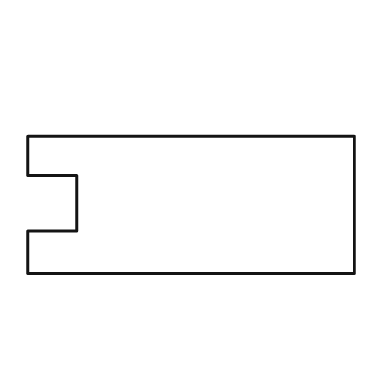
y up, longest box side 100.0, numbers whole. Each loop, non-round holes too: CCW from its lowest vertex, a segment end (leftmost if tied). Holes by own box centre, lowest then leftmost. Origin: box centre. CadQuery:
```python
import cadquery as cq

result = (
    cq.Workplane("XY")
    .moveTo(-50.0, -21.0)
    .lineTo(50.0, -21.0)
    .lineTo(50.0, 21.0)
    .lineTo(-50.0, 21.0)
    .lineTo(-50.0, 9.0)
    .lineTo(-35.0, 9.0)
    .lineTo(-35.0, -8.0)
    .lineTo(-50.0, -8.0)
    .close()
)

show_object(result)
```